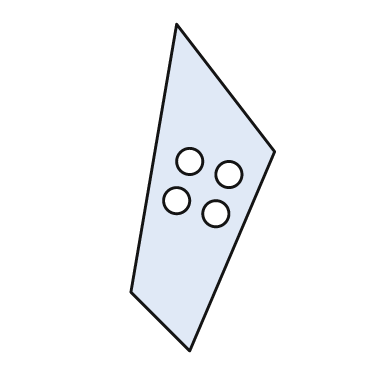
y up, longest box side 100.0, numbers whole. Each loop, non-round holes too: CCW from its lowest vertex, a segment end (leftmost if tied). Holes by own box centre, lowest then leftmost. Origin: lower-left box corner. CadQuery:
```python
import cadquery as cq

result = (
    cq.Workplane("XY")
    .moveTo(18.0, 0.0)
    .lineTo(44.0, 61.0)
    .lineTo(14.0, 100.0)
    .lineTo(0.0, 18.0)
    .close()
    .moveTo(26.0, 42.0)
    .circle(4.0)
    .moveTo(14.0, 46.0)
    .circle(4.0)
    .moveTo(30.0, 54.0)
    .circle(4.0)
    .moveTo(18.0, 58.0)
    .circle(4.0)
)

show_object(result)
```